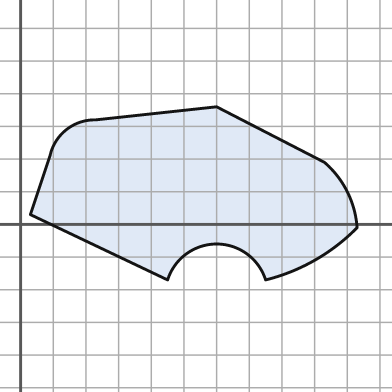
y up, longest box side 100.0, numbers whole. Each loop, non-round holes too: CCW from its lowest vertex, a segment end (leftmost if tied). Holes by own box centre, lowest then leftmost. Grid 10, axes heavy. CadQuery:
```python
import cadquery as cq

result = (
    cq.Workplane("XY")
    .moveTo(45.0, -17.0)
    .threePointArc((60.0, -6.0), (75.0, -17.0))
    .threePointArc((90.0, -11.0), (103.0, -1.0))
    .threePointArc((100.0, 10.0), (93.0, 19.0))
    .lineTo(60.0, 36.0)
    .lineTo(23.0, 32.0)
    .threePointArc((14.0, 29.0), (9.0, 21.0))
    .lineTo(3.0, 3.0)
    .close()
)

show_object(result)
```